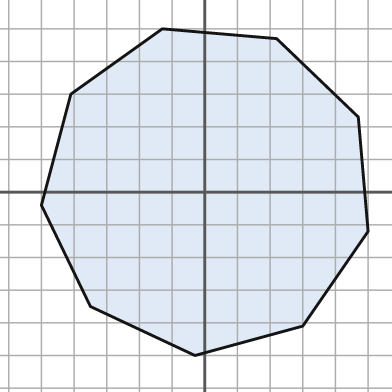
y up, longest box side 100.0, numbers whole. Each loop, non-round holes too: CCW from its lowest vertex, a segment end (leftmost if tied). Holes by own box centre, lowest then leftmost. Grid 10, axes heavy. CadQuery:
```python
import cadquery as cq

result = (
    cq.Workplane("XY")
    .moveTo(-3.0, -50.0)
    .lineTo(30.0, -41.0)
    .lineTo(50.0, -12.0)
    .lineTo(47.0, 23.0)
    .lineTo(22.0, 47.0)
    .lineTo(-13.0, 50.0)
    .lineTo(-41.0, 30.0)
    .lineTo(-50.0, -4.0)
    .lineTo(-35.0, -35.0)
    .close()
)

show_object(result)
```